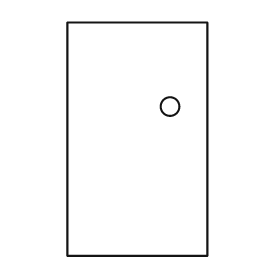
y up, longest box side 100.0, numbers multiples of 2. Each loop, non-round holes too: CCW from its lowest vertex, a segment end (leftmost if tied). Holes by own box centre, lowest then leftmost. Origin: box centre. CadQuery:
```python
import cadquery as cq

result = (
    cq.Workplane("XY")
    .moveTo(-30.0, -50.0)
    .lineTo(30.0, -50.0)
    .lineTo(30.0, 50.0)
    .lineTo(-30.0, 50.0)
    .close()
    .moveTo(14.0, 14.0)
    .circle(4.0)
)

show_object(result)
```